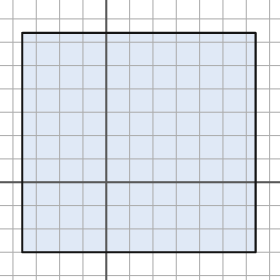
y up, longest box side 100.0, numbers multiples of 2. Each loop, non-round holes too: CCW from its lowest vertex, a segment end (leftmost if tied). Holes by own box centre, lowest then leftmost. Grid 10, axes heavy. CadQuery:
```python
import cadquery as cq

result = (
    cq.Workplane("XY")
    .moveTo(-36.0, -30.0)
    .lineTo(64.0, -30.0)
    .lineTo(64.0, 64.0)
    .lineTo(-36.0, 64.0)
    .close()
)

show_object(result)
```